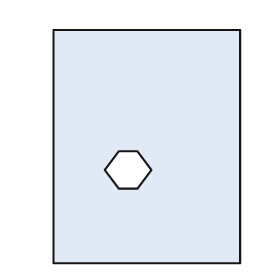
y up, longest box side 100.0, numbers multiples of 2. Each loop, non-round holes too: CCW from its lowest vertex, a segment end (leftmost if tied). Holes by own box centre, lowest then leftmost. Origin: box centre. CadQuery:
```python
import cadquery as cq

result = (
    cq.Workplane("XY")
    .moveTo(-40.0, -50.0)
    .lineTo(40.0, -50.0)
    .lineTo(40.0, 50.0)
    .lineTo(-40.0, 50.0)
    .close()
    .moveTo(-12.0, -18.0)
    .lineTo(-4.0, -18.0)
    .lineTo(2.0, -10.0)
    .lineTo(-4.0, -2.0)
    .lineTo(-12.0, -2.0)
    .lineTo(-18.0, -10.0)
    .close()
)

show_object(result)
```